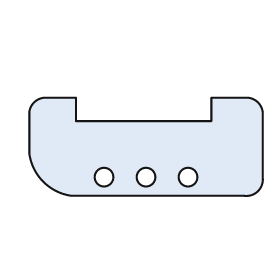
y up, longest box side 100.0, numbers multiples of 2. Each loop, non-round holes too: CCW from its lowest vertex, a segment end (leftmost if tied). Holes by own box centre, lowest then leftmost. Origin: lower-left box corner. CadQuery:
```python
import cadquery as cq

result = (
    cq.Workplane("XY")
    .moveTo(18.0, 0.0)
    .lineTo(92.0, 0.0)
    .threePointArc((98.0, 2.0), (100.0, 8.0))
    .lineTo(100.0, 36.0)
    .threePointArc((98.0, 40.0), (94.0, 42.0))
    .lineTo(78.0, 42.0)
    .lineTo(78.0, 32.0)
    .lineTo(20.0, 32.0)
    .lineTo(20.0, 42.0)
    .lineTo(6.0, 42.0)
    .threePointArc((2.0, 40.0), (0.0, 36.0))
    .lineTo(0.0, 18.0)
    .threePointArc((6.0, 6.0), (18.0, 0.0))
    .close()
    .moveTo(32.0, 8.0)
    .circle(4.0)
    .moveTo(50.0, 8.0)
    .circle(4.0)
    .moveTo(68.0, 8.0)
    .circle(4.0)
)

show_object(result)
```